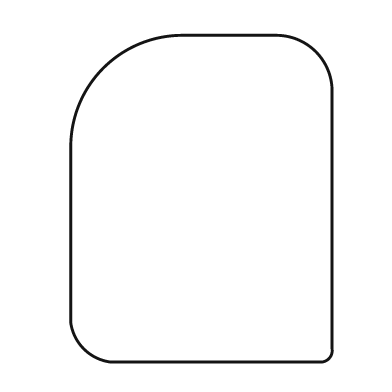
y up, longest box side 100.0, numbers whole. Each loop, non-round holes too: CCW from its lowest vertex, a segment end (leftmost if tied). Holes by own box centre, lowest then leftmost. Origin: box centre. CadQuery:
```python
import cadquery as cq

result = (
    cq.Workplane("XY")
    .moveTo(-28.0, -50.0)
    .lineTo(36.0, -50.0)
    .threePointArc((39.0, -49.0), (40.0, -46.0))
    .lineTo(40.0, 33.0)
    .threePointArc((35.0, 45.0), (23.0, 50.0))
    .lineTo(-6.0, 50.0)
    .threePointArc((-30.0, 40.0), (-40.0, 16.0))
    .lineTo(-40.0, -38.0)
    .threePointArc((-36.0, -46.0), (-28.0, -50.0))
    .close()
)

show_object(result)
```